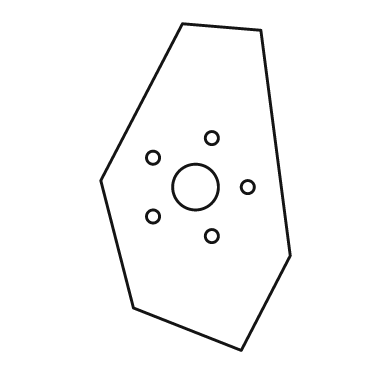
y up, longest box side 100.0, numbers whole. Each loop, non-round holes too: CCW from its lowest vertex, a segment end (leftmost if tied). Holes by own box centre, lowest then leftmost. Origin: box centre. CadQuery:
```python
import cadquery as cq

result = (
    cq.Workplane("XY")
    .moveTo(14.0, -50.0)
    .lineTo(29.0, -21.0)
    .lineTo(20.0, 48.0)
    .lineTo(-4.0, 50.0)
    .lineTo(-29.0, 2.0)
    .lineTo(-19.0, -37.0)
    .close()
    .moveTo(5.0, -15.0)
    .circle(2.0)
    .moveTo(-13.0, -9.0)
    .circle(2.0)
    .moveTo(0.0, 0.0)
    .circle(7.0)
    .moveTo(16.0, 0.0)
    .circle(2.0)
    .moveTo(-13.0, 9.0)
    .circle(2.0)
    .moveTo(5.0, 15.0)
    .circle(2.0)
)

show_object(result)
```